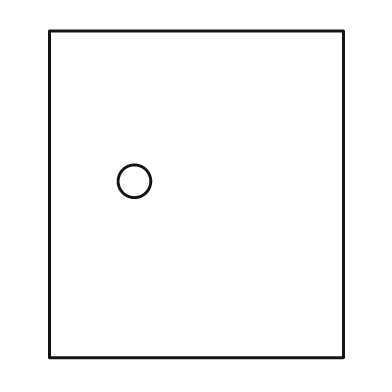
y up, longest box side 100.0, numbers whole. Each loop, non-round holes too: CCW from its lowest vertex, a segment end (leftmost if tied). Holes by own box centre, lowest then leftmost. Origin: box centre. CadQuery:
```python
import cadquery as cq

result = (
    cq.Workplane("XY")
    .moveTo(-45.0, -50.0)
    .lineTo(45.0, -50.0)
    .lineTo(45.0, 50.0)
    .lineTo(-45.0, 50.0)
    .close()
    .moveTo(-19.0, 4.0)
    .circle(5.0)
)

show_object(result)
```